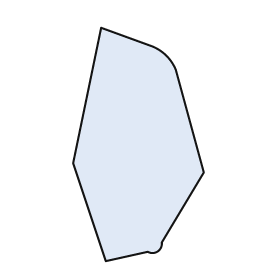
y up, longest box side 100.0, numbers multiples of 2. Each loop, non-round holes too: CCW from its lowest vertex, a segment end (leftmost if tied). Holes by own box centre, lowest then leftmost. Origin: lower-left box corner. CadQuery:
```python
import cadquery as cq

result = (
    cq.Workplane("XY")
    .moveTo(14.0, 0.0)
    .lineTo(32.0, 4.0)
    .threePointArc((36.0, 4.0), (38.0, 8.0))
    .lineTo(56.0, 38.0)
    .lineTo(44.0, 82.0)
    .threePointArc((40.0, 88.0), (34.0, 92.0))
    .lineTo(12.0, 100.0)
    .lineTo(0.0, 42.0)
    .close()
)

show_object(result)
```